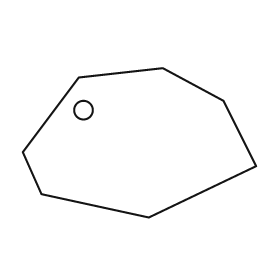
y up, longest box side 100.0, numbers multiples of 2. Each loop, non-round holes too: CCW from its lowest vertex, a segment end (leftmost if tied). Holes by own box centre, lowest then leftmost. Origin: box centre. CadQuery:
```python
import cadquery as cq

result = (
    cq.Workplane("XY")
    .moveTo(4.0, -32.0)
    .lineTo(50.0, -10.0)
    .lineTo(36.0, 18.0)
    .lineTo(10.0, 32.0)
    .lineTo(-26.0, 28.0)
    .lineTo(-50.0, -4.0)
    .lineTo(-42.0, -22.0)
    .close()
    .moveTo(-24.0, 14.0)
    .circle(4.0)
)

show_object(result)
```